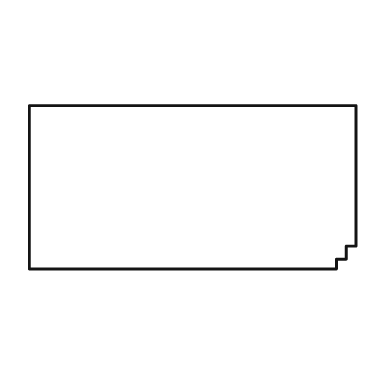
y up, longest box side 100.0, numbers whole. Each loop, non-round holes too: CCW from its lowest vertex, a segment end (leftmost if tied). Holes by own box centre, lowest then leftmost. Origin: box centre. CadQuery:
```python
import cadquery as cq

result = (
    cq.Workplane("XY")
    .moveTo(-50.0, -25.0)
    .lineTo(44.0, -25.0)
    .lineTo(44.0, -22.0)
    .lineTo(47.0, -22.0)
    .lineTo(47.0, -18.0)
    .lineTo(50.0, -18.0)
    .lineTo(50.0, 25.0)
    .lineTo(-50.0, 25.0)
    .close()
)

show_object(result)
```